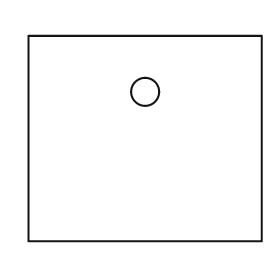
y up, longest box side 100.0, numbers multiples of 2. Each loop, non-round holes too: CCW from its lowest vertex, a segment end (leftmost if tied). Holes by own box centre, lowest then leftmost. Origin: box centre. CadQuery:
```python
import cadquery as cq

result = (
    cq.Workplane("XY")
    .moveTo(-50.0, -44.0)
    .lineTo(50.0, -44.0)
    .lineTo(50.0, 44.0)
    .lineTo(-50.0, 44.0)
    .close()
    .moveTo(0.0, 20.0)
    .circle(6.0)
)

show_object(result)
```